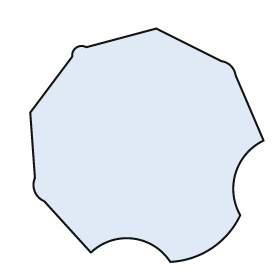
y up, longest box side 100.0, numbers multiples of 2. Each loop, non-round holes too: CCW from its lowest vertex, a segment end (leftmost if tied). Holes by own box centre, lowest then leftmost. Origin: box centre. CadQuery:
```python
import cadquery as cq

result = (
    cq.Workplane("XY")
    .moveTo(10.0, -50.0)
    .threePointArc((28.0, -44.0), (40.0, -30.0))
    .threePointArc((38.0, -12.0), (50.0, 2.0))
    .lineTo(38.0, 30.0)
    .threePointArc((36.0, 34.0), (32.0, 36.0))
    .lineTo(4.0, 50.0)
    .lineTo(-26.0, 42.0)
    .threePointArc((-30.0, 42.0), (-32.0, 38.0))
    .lineTo(-50.0, 14.0)
    .lineTo(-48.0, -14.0)
    .threePointArc((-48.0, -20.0), (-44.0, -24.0))
    .lineTo(-24.0, -46.0)
    .threePointArc((-6.0, -40.0), (10.0, -50.0))
    .close()
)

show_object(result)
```